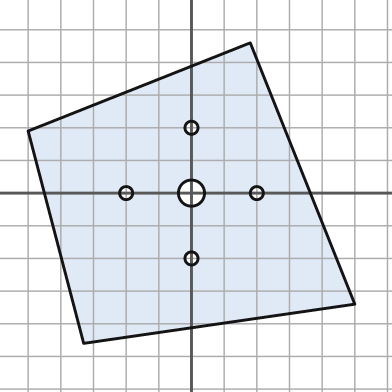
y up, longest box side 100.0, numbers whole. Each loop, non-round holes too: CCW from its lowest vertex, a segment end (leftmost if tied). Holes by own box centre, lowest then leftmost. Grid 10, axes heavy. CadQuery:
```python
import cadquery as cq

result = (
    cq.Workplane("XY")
    .moveTo(-33.0, -46.0)
    .lineTo(50.0, -34.0)
    .lineTo(18.0, 46.0)
    .lineTo(-50.0, 19.0)
    .close()
    .moveTo(0.0, -20.0)
    .circle(2.0)
    .moveTo(-20.0, 0.0)
    .circle(2.0)
    .moveTo(0.0, 0.0)
    .circle(4.0)
    .moveTo(20.0, 0.0)
    .circle(2.0)
    .moveTo(0.0, 20.0)
    .circle(2.0)
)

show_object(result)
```